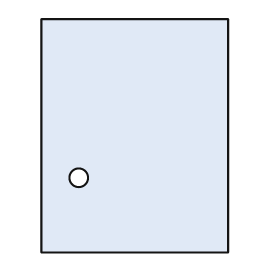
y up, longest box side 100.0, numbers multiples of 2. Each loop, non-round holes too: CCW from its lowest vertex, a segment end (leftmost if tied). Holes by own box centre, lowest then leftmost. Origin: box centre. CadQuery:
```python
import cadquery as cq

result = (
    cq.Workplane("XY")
    .moveTo(-40.0, -50.0)
    .lineTo(40.0, -50.0)
    .lineTo(40.0, 50.0)
    .lineTo(-40.0, 50.0)
    .close()
    .moveTo(-24.0, -18.0)
    .circle(4.0)
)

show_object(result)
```